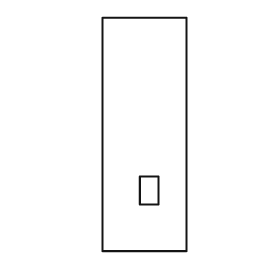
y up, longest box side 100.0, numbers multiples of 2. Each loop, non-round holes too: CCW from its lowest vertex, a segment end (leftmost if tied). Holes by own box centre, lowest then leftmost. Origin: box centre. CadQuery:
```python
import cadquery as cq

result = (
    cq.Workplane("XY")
    .moveTo(-18.0, -50.0)
    .lineTo(18.0, -50.0)
    .lineTo(18.0, 50.0)
    .lineTo(-18.0, 50.0)
    .close()
    .moveTo(-2.0, -30.0)
    .lineTo(6.0, -30.0)
    .lineTo(6.0, -18.0)
    .lineTo(-2.0, -18.0)
    .close()
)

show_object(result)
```